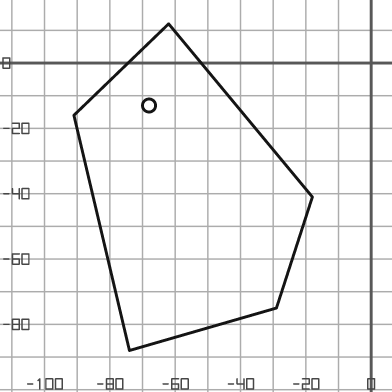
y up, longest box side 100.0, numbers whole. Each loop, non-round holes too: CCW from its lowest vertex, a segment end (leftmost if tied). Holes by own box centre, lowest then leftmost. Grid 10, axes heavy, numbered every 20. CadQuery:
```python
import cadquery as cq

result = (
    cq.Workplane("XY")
    .moveTo(-74.0, -88.0)
    .lineTo(-29.0, -75.0)
    .lineTo(-18.0, -41.0)
    .lineTo(-62.0, 12.0)
    .lineTo(-91.0, -16.0)
    .close()
    .moveTo(-68.0, -13.0)
    .circle(2.0)
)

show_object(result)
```